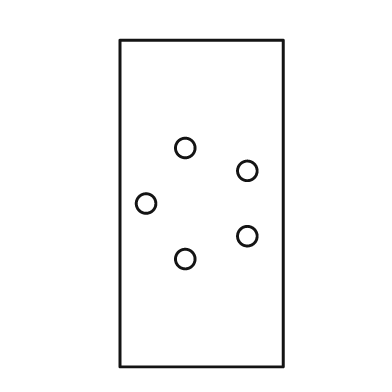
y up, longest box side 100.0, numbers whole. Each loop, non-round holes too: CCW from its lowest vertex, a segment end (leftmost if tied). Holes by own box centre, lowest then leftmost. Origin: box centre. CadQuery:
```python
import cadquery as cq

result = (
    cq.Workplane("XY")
    .moveTo(-25.0, -50.0)
    .lineTo(25.0, -50.0)
    .lineTo(25.0, 50.0)
    .lineTo(-25.0, 50.0)
    .close()
    .moveTo(-5.0, -17.0)
    .circle(3.0)
    .moveTo(14.0, -10.0)
    .circle(3.0)
    .moveTo(-17.0, 0.0)
    .circle(3.0)
    .moveTo(14.0, 10.0)
    .circle(3.0)
    .moveTo(-5.0, 17.0)
    .circle(3.0)
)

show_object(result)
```